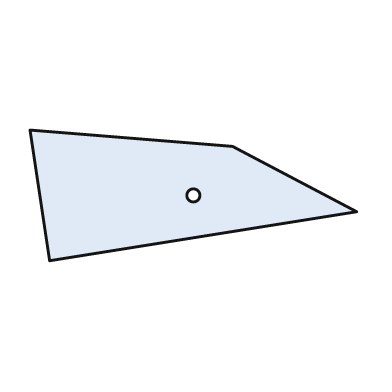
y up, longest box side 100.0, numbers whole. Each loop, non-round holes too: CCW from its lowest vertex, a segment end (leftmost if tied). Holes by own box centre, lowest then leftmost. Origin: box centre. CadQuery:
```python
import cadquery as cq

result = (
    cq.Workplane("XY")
    .moveTo(-44.0, -20.0)
    .lineTo(50.0, -5.0)
    .lineTo(12.0, 15.0)
    .lineTo(-50.0, 20.0)
    .close()
    .moveTo(0.0, 0.0)
    .circle(2.0)
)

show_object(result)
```